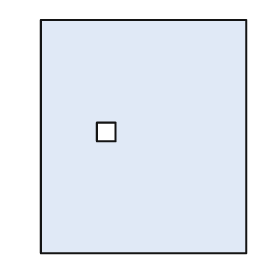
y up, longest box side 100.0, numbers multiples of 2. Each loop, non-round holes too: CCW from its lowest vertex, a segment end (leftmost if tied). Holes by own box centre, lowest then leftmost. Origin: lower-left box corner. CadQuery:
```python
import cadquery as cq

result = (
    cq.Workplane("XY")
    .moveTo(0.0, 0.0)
    .lineTo(88.0, 0.0)
    .lineTo(88.0, 100.0)
    .lineTo(0.0, 100.0)
    .close()
    .moveTo(24.0, 48.0)
    .lineTo(32.0, 48.0)
    .lineTo(32.0, 56.0)
    .lineTo(24.0, 56.0)
    .close()
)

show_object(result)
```